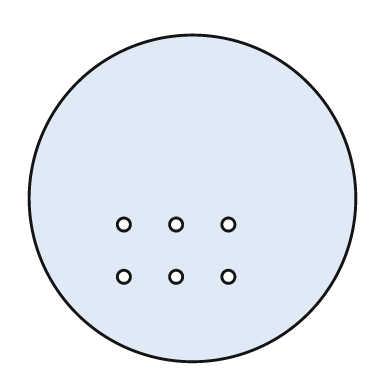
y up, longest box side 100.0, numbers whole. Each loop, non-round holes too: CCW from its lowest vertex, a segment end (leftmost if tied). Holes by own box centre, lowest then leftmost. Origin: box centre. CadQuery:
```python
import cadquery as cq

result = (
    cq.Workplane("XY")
    .moveTo(0.0, 0.0)
    .circle(50.0)
    .moveTo(-21.0, -24.0)
    .circle(2.0)
    .moveTo(-5.0, -24.0)
    .circle(2.0)
    .moveTo(11.0, -24.0)
    .circle(2.0)
    .moveTo(-21.0, -8.0)
    .circle(2.0)
    .moveTo(-5.0, -8.0)
    .circle(2.0)
    .moveTo(11.0, -8.0)
    .circle(2.0)
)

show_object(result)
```